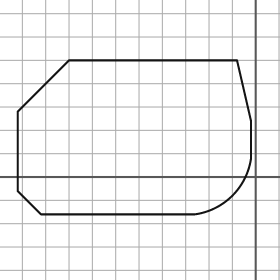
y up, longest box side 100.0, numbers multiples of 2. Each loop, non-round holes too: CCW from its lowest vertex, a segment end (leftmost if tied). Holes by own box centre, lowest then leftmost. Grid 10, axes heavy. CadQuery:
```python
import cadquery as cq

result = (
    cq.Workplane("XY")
    .moveTo(-92.0, -16.0)
    .lineTo(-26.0, -16.0)
    .threePointArc((-10.0, -8.0), (-2.0, 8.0))
    .lineTo(-2.0, 24.0)
    .lineTo(-8.0, 50.0)
    .lineTo(-80.0, 50.0)
    .lineTo(-102.0, 28.0)
    .lineTo(-102.0, -6.0)
    .close()
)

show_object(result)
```